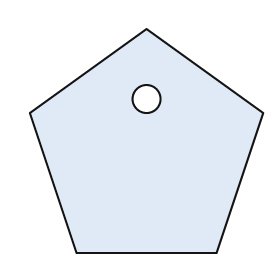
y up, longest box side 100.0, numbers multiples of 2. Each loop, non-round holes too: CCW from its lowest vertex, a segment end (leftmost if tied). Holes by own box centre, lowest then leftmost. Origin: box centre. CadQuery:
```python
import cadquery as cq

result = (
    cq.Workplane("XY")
    .moveTo(-30.0, -48.0)
    .lineTo(30.0, -48.0)
    .lineTo(50.0, 12.0)
    .lineTo(0.0, 48.0)
    .lineTo(-50.0, 12.0)
    .close()
    .moveTo(0.0, 18.0)
    .circle(6.0)
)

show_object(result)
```